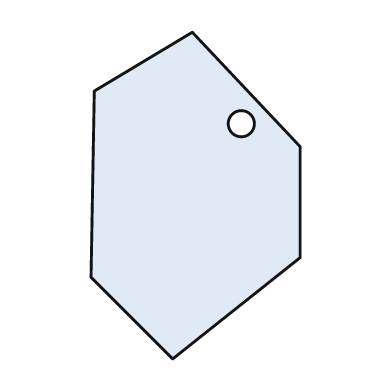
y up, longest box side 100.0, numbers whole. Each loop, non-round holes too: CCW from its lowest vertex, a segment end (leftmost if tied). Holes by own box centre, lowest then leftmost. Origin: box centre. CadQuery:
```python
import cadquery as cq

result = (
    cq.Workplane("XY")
    .moveTo(-7.0, -50.0)
    .lineTo(32.0, -19.0)
    .lineTo(32.0, 15.0)
    .lineTo(-1.0, 50.0)
    .lineTo(-31.0, 32.0)
    .lineTo(-32.0, -25.0)
    .close()
    .moveTo(14.0, 22.0)
    .circle(4.0)
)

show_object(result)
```